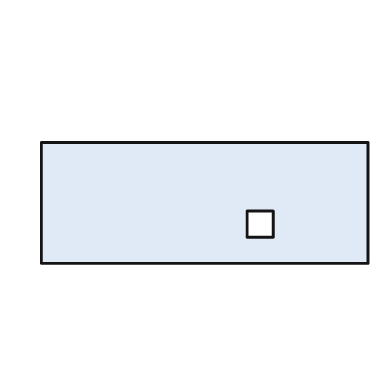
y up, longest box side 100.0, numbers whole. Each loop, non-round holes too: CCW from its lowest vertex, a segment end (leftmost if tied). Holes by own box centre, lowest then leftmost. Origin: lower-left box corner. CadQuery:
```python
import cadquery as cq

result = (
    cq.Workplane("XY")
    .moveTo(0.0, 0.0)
    .lineTo(100.0, 0.0)
    .lineTo(100.0, 37.0)
    .lineTo(0.0, 37.0)
    .close()
    .moveTo(63.0, 8.0)
    .lineTo(71.0, 8.0)
    .lineTo(71.0, 16.0)
    .lineTo(63.0, 16.0)
    .close()
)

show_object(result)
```